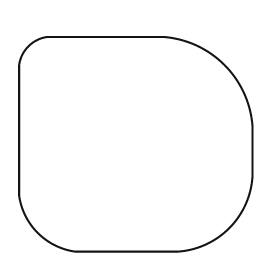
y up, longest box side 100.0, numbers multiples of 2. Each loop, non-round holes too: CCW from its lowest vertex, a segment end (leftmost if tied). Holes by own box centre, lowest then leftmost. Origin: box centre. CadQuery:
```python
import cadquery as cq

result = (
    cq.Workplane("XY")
    .moveTo(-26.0, -46.0)
    .lineTo(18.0, -46.0)
    .threePointArc((40.0, -36.0), (50.0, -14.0))
    .lineTo(50.0, 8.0)
    .threePointArc((38.0, 34.0), (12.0, 46.0))
    .lineTo(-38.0, 46.0)
    .threePointArc((-46.0, 42.0), (-50.0, 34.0))
    .lineTo(-50.0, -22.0)
    .threePointArc((-42.0, -38.0), (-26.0, -46.0))
    .close()
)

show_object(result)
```